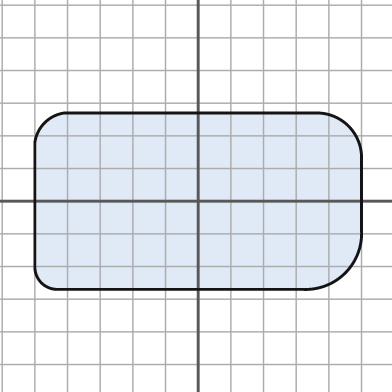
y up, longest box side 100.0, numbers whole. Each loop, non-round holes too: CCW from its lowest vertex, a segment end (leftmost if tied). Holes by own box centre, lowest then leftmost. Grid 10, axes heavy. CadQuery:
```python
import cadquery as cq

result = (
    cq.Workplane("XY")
    .moveTo(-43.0, -27.0)
    .lineTo(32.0, -27.0)
    .threePointArc((45.0, -22.0), (50.0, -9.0))
    .lineTo(50.0, 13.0)
    .threePointArc((46.0, 23.0), (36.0, 27.0))
    .lineTo(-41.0, 27.0)
    .threePointArc((-47.0, 24.0), (-50.0, 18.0))
    .lineTo(-50.0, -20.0)
    .threePointArc((-48.0, -25.0), (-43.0, -27.0))
    .close()
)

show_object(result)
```